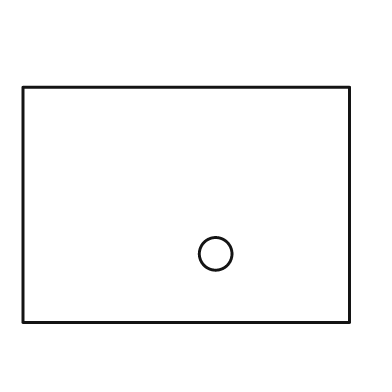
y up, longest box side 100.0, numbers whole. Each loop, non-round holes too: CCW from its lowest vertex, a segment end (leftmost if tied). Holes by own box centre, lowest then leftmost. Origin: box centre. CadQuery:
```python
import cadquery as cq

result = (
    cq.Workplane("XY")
    .moveTo(-50.0, -36.0)
    .lineTo(50.0, -36.0)
    .lineTo(50.0, 36.0)
    .lineTo(-50.0, 36.0)
    .close()
    .moveTo(9.0, -15.0)
    .circle(5.0)
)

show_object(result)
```